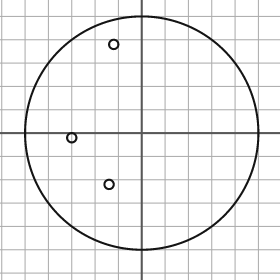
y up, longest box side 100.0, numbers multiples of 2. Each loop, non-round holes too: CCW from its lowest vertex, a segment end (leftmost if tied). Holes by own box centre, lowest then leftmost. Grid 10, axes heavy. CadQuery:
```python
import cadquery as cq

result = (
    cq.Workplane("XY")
    .moveTo(0.0, 0.0)
    .circle(50.0)
    .moveTo(-14.0, -22.0)
    .circle(2.0)
    .moveTo(-30.0, -2.0)
    .circle(2.0)
    .moveTo(-12.0, 38.0)
    .circle(2.0)
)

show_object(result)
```